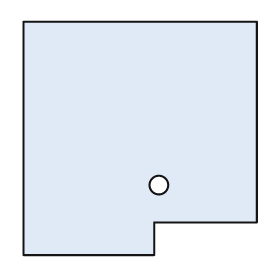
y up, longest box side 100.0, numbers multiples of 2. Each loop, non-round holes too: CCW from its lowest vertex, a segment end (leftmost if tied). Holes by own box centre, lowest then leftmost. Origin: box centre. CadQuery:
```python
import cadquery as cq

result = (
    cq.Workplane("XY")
    .moveTo(-50.0, -50.0)
    .lineTo(6.0, -50.0)
    .lineTo(6.0, -36.0)
    .lineTo(50.0, -36.0)
    .lineTo(50.0, 50.0)
    .lineTo(-50.0, 50.0)
    .close()
    .moveTo(8.0, -20.0)
    .circle(4.0)
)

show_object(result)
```